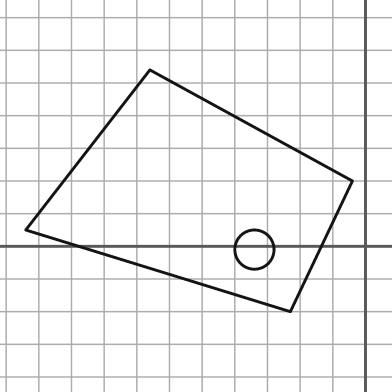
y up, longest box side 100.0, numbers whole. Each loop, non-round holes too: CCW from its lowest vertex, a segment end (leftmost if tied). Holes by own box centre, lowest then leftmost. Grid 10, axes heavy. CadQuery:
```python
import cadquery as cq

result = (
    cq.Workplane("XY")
    .moveTo(-23.0, -20.0)
    .lineTo(-4.0, 20.0)
    .lineTo(-66.0, 54.0)
    .lineTo(-104.0, 5.0)
    .close()
    .moveTo(-34.0, -1.0)
    .circle(6.0)
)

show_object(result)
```